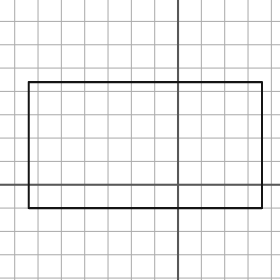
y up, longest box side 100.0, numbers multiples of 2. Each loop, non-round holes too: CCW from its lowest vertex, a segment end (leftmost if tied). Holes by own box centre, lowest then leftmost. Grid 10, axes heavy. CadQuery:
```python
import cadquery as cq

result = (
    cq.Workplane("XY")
    .moveTo(-64.0, -10.0)
    .lineTo(36.0, -10.0)
    .lineTo(36.0, 44.0)
    .lineTo(-64.0, 44.0)
    .close()
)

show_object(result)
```